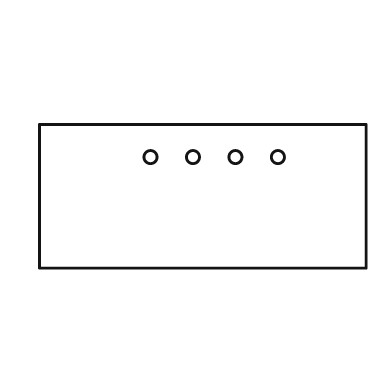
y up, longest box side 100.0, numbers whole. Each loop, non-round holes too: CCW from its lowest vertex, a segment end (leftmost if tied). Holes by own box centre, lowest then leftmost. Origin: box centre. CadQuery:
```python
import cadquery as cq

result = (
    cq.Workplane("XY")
    .moveTo(-50.0, -22.0)
    .lineTo(50.0, -22.0)
    .lineTo(50.0, 22.0)
    .lineTo(-50.0, 22.0)
    .close()
    .moveTo(-16.0, 12.0)
    .circle(2.0)
    .moveTo(-3.0, 12.0)
    .circle(2.0)
    .moveTo(10.0, 12.0)
    .circle(2.0)
    .moveTo(23.0, 12.0)
    .circle(2.0)
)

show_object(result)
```